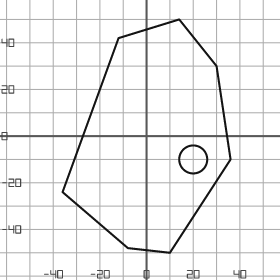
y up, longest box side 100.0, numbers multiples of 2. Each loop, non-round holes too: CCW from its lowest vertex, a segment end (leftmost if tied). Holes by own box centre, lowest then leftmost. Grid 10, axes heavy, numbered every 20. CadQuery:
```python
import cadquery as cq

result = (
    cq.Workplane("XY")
    .moveTo(10.0, -50.0)
    .lineTo(36.0, -10.0)
    .lineTo(30.0, 30.0)
    .lineTo(14.0, 50.0)
    .lineTo(-12.0, 42.0)
    .lineTo(-36.0, -24.0)
    .lineTo(-8.0, -48.0)
    .close()
    .moveTo(20.0, -10.0)
    .circle(6.0)
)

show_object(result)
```